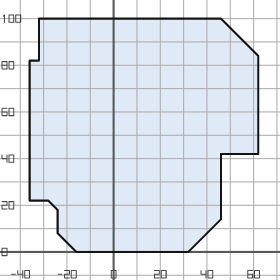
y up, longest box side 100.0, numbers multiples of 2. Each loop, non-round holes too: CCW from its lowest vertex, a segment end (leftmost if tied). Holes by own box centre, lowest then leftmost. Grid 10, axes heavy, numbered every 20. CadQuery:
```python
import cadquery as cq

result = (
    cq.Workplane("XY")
    .moveTo(-16.0, 0.0)
    .lineTo(32.0, 0.0)
    .lineTo(46.0, 14.0)
    .lineTo(46.0, 42.0)
    .lineTo(62.0, 42.0)
    .lineTo(62.0, 84.0)
    .lineTo(46.0, 100.0)
    .lineTo(-32.0, 100.0)
    .lineTo(-32.0, 82.0)
    .lineTo(-36.0, 82.0)
    .lineTo(-36.0, 22.0)
    .lineTo(-28.0, 22.0)
    .lineTo(-24.0, 18.0)
    .lineTo(-24.0, 8.0)
    .close()
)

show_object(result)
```